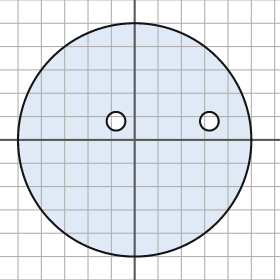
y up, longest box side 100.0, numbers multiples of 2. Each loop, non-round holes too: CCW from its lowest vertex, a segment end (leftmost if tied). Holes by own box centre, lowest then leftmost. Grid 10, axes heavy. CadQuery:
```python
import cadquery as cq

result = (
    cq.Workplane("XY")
    .moveTo(0.0, 0.0)
    .circle(50.0)
    .moveTo(-8.0, 8.0)
    .circle(4.0)
    .moveTo(32.0, 8.0)
    .circle(4.0)
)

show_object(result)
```